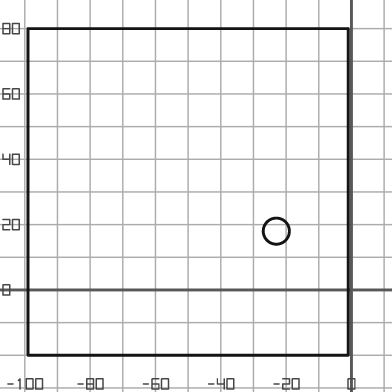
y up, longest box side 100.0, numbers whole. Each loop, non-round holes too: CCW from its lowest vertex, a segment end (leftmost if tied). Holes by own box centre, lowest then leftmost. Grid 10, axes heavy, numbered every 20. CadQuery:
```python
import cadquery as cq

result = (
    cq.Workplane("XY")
    .moveTo(-99.0, -20.0)
    .lineTo(-1.0, -20.0)
    .lineTo(-1.0, 80.0)
    .lineTo(-99.0, 80.0)
    .close()
    .moveTo(-23.0, 18.0)
    .circle(4.0)
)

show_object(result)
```